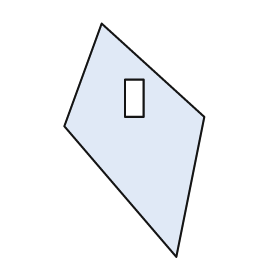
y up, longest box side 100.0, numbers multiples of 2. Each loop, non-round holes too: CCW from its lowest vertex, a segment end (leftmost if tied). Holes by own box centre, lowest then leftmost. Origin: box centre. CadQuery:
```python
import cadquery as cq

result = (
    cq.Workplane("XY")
    .moveTo(18.0, -50.0)
    .lineTo(30.0, 10.0)
    .lineTo(-14.0, 50.0)
    .lineTo(-30.0, 6.0)
    .close()
    .moveTo(-4.0, 10.0)
    .lineTo(4.0, 10.0)
    .lineTo(4.0, 26.0)
    .lineTo(-4.0, 26.0)
    .close()
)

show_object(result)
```